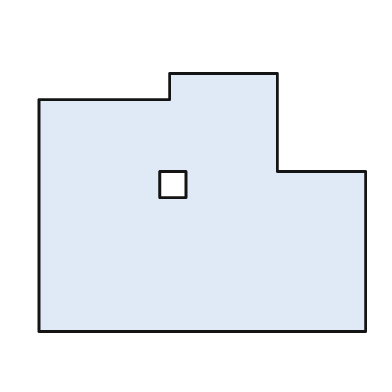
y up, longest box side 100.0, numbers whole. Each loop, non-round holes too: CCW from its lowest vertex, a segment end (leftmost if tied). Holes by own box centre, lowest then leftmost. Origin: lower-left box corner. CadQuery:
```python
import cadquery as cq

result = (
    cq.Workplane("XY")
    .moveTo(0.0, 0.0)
    .lineTo(100.0, 0.0)
    .lineTo(100.0, 49.0)
    .lineTo(73.0, 49.0)
    .lineTo(73.0, 79.0)
    .lineTo(40.0, 79.0)
    .lineTo(40.0, 71.0)
    .lineTo(0.0, 71.0)
    .close()
    .moveTo(37.0, 41.0)
    .lineTo(45.0, 41.0)
    .lineTo(45.0, 49.0)
    .lineTo(37.0, 49.0)
    .close()
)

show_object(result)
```